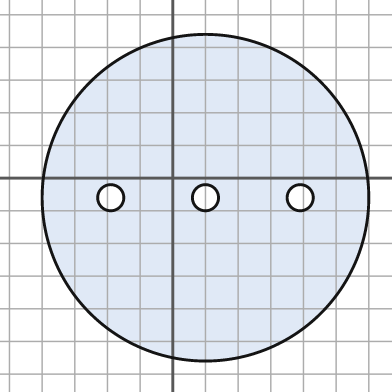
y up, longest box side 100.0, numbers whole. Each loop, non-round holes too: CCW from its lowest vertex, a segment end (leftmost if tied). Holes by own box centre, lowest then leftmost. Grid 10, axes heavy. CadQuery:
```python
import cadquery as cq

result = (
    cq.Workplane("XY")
    .moveTo(10.0, -6.0)
    .circle(50.0)
    .moveTo(-19.0, -6.0)
    .circle(4.0)
    .moveTo(10.0, -6.0)
    .circle(4.0)
    .moveTo(39.0, -6.0)
    .circle(4.0)
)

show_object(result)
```